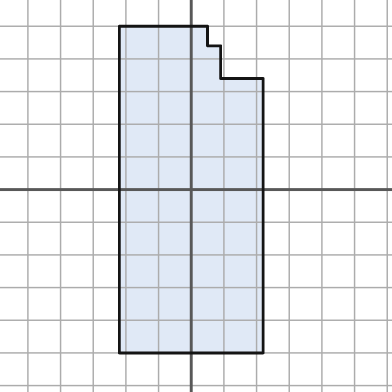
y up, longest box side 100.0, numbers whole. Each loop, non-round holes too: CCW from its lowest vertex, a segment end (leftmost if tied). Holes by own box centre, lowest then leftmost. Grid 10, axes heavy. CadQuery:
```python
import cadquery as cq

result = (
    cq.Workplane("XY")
    .moveTo(-22.0, -50.0)
    .lineTo(22.0, -50.0)
    .lineTo(22.0, 34.0)
    .lineTo(9.0, 34.0)
    .lineTo(9.0, 44.0)
    .lineTo(5.0, 44.0)
    .lineTo(5.0, 50.0)
    .lineTo(-22.0, 50.0)
    .close()
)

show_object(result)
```